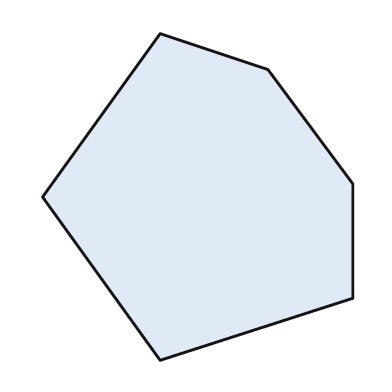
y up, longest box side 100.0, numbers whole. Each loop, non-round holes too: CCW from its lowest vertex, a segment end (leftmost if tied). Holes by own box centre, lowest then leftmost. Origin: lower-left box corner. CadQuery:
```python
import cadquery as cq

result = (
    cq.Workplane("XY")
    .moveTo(36.0, 0.0)
    .lineTo(95.0, 19.0)
    .lineTo(95.0, 54.0)
    .lineTo(69.0, 89.0)
    .lineTo(36.0, 100.0)
    .lineTo(0.0, 50.0)
    .close()
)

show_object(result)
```